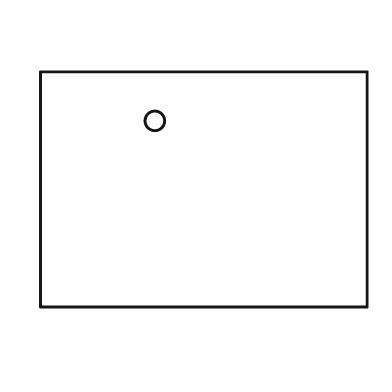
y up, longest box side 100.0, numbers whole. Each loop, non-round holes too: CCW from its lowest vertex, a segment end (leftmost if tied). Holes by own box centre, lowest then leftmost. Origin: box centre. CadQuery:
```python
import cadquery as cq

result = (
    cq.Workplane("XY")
    .moveTo(-50.0, -36.0)
    .lineTo(50.0, -36.0)
    .lineTo(50.0, 36.0)
    .lineTo(-50.0, 36.0)
    .close()
    .moveTo(-15.0, 21.0)
    .circle(3.0)
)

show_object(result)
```